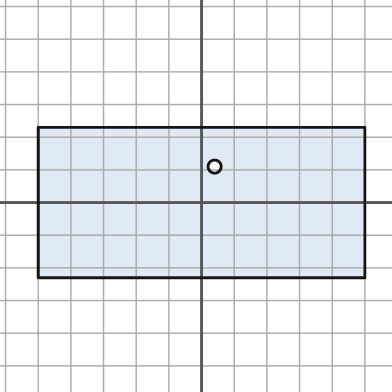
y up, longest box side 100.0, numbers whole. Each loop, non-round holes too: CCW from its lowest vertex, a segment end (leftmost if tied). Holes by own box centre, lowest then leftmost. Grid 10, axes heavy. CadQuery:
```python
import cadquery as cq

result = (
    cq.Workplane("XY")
    .moveTo(-50.0, -23.0)
    .lineTo(50.0, -23.0)
    .lineTo(50.0, 23.0)
    .lineTo(-50.0, 23.0)
    .close()
    .moveTo(4.0, 11.0)
    .circle(2.0)
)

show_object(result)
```